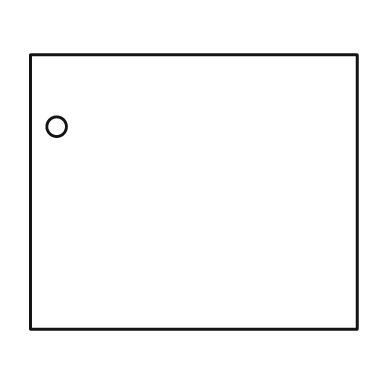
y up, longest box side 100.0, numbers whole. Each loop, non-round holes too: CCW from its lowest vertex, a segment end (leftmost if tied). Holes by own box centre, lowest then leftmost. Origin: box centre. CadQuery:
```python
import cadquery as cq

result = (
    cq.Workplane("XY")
    .moveTo(-50.0, -42.0)
    .lineTo(50.0, -42.0)
    .lineTo(50.0, 42.0)
    .lineTo(-50.0, 42.0)
    .close()
    .moveTo(-42.0, 20.0)
    .circle(3.0)
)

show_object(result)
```